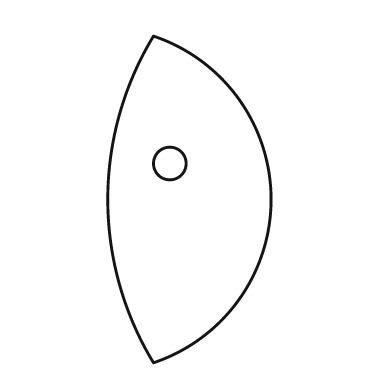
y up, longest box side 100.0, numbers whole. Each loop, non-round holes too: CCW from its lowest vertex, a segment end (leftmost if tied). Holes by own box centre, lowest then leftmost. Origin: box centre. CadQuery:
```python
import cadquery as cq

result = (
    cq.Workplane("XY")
    .moveTo(-11.0, -50.0)
    .threePointArc((25.0, 0.0), (-11.0, 50.0))
    .threePointArc((-25.0, 0.0), (-11.0, -50.0))
    .close()
    .moveTo(-6.0, 11.0)
    .circle(5.0)
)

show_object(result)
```